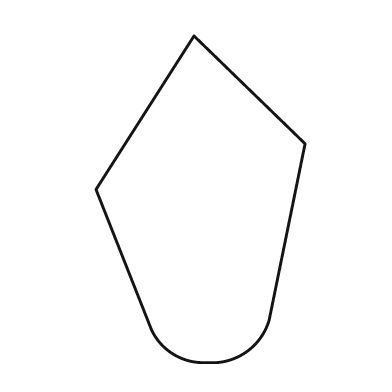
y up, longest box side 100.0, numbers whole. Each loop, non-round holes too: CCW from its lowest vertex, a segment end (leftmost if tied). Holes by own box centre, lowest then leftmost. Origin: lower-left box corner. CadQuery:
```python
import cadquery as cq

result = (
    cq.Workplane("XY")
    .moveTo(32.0, 0.0)
    .lineTo(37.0, 0.0)
    .threePointArc((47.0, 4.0), (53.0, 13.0))
    .lineTo(64.0, 67.0)
    .lineTo(30.0, 100.0)
    .lineTo(0.0, 53.0)
    .lineTo(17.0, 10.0)
    .threePointArc((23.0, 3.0), (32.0, 0.0))
    .close()
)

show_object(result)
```